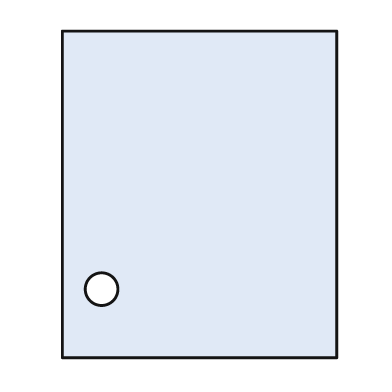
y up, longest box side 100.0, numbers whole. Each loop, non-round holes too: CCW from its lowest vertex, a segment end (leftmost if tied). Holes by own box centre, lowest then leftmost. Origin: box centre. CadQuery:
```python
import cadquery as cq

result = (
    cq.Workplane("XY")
    .moveTo(-42.0, -50.0)
    .lineTo(42.0, -50.0)
    .lineTo(42.0, 50.0)
    .lineTo(-42.0, 50.0)
    .close()
    .moveTo(-30.0, -29.0)
    .circle(5.0)
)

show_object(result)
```